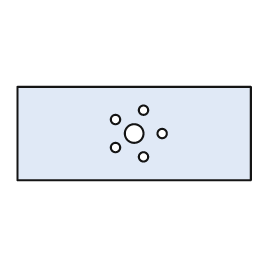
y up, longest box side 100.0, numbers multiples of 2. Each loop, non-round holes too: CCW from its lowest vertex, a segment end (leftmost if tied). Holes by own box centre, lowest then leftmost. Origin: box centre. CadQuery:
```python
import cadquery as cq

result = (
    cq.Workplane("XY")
    .moveTo(-50.0, -20.0)
    .lineTo(50.0, -20.0)
    .lineTo(50.0, 20.0)
    .lineTo(-50.0, 20.0)
    .close()
    .moveTo(4.0, -10.0)
    .circle(2.0)
    .moveTo(-8.0, -6.0)
    .circle(2.0)
    .moveTo(0.0, 0.0)
    .circle(4.0)
    .moveTo(12.0, 0.0)
    .circle(2.0)
    .moveTo(-8.0, 6.0)
    .circle(2.0)
    .moveTo(4.0, 10.0)
    .circle(2.0)
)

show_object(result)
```